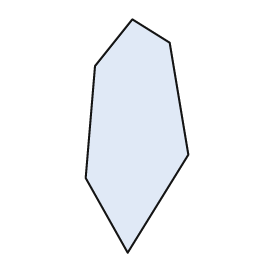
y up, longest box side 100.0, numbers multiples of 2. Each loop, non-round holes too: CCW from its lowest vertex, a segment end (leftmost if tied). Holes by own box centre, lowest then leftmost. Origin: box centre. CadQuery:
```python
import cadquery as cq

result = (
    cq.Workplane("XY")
    .moveTo(-4.0, -50.0)
    .lineTo(22.0, -8.0)
    .lineTo(14.0, 40.0)
    .lineTo(-2.0, 50.0)
    .lineTo(-18.0, 30.0)
    .lineTo(-22.0, -18.0)
    .close()
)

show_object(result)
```